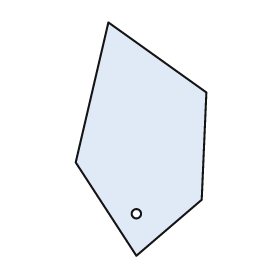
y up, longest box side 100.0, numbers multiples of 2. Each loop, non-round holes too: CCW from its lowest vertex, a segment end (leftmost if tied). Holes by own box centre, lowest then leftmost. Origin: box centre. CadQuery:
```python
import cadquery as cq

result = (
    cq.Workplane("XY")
    .moveTo(-2.0, -50.0)
    .lineTo(26.0, -26.0)
    .lineTo(28.0, 20.0)
    .lineTo(-14.0, 50.0)
    .lineTo(-28.0, -10.0)
    .close()
    .moveTo(-2.0, -32.0)
    .circle(2.0)
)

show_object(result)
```